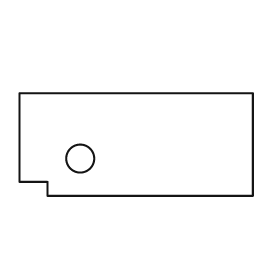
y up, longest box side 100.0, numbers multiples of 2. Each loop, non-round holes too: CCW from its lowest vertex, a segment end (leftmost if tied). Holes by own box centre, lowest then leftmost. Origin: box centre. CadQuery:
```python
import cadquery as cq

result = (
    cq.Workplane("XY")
    .moveTo(-38.0, -22.0)
    .lineTo(50.0, -22.0)
    .lineTo(50.0, 22.0)
    .lineTo(-50.0, 22.0)
    .lineTo(-50.0, -16.0)
    .lineTo(-38.0, -16.0)
    .close()
    .moveTo(-24.0, -6.0)
    .circle(6.0)
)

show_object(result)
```